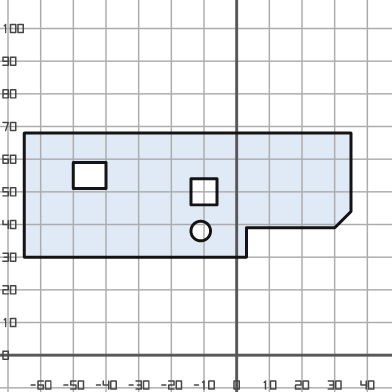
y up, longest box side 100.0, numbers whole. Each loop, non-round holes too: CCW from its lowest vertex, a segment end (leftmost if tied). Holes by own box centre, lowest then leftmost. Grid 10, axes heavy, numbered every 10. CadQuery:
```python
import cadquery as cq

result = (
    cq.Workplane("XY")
    .moveTo(-65.0, 30.0)
    .lineTo(3.0, 30.0)
    .lineTo(3.0, 39.0)
    .lineTo(30.0, 39.0)
    .lineTo(35.0, 44.0)
    .lineTo(35.0, 68.0)
    .lineTo(-65.0, 68.0)
    .close()
    .moveTo(-11.0, 38.0)
    .circle(3.0)
    .moveTo(-14.0, 46.0)
    .lineTo(-6.0, 46.0)
    .lineTo(-6.0, 54.0)
    .lineTo(-14.0, 54.0)
    .close()
    .moveTo(-50.0, 51.0)
    .lineTo(-40.0, 51.0)
    .lineTo(-40.0, 59.0)
    .lineTo(-50.0, 59.0)
    .close()
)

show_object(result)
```